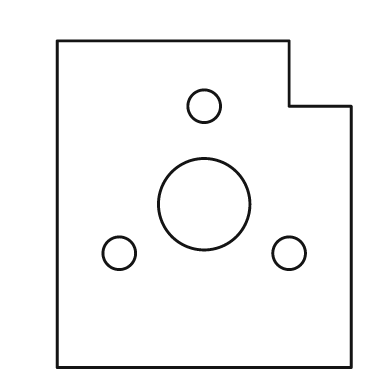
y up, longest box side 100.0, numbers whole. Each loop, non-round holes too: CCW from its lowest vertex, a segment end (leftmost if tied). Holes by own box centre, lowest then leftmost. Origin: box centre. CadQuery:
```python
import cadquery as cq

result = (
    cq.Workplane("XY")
    .moveTo(-45.0, -50.0)
    .lineTo(45.0, -50.0)
    .lineTo(45.0, 30.0)
    .lineTo(26.0, 30.0)
    .lineTo(26.0, 50.0)
    .lineTo(-45.0, 50.0)
    .close()
    .moveTo(-26.0, -15.0)
    .circle(5.0)
    .moveTo(26.0, -15.0)
    .circle(5.0)
    .moveTo(0.0, 0.0)
    .circle(14.0)
    .moveTo(0.0, 30.0)
    .circle(5.0)
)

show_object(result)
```